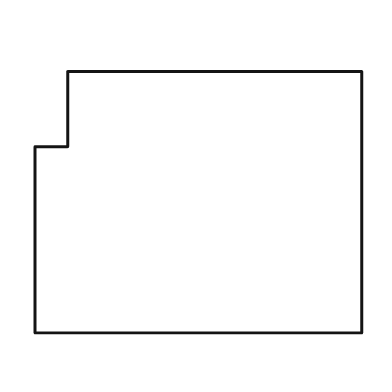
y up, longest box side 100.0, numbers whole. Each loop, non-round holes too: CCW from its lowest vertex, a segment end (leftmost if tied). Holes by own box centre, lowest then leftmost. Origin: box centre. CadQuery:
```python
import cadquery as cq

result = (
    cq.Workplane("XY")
    .moveTo(-50.0, -40.0)
    .lineTo(50.0, -40.0)
    .lineTo(50.0, 40.0)
    .lineTo(-40.0, 40.0)
    .lineTo(-40.0, 17.0)
    .lineTo(-50.0, 17.0)
    .close()
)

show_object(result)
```